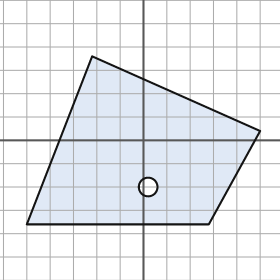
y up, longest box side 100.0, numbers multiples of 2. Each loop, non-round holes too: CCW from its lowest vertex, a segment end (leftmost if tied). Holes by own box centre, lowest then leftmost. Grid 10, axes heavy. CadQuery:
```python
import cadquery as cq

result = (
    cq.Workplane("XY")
    .moveTo(-50.0, -36.0)
    .lineTo(28.0, -36.0)
    .lineTo(50.0, 4.0)
    .lineTo(-22.0, 36.0)
    .close()
    .moveTo(2.0, -20.0)
    .circle(4.0)
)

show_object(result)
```